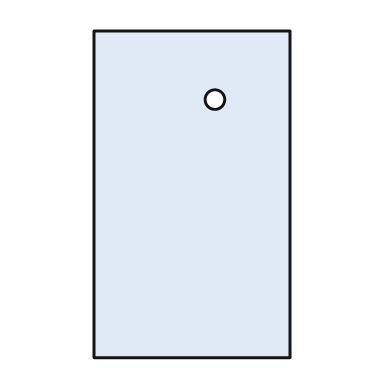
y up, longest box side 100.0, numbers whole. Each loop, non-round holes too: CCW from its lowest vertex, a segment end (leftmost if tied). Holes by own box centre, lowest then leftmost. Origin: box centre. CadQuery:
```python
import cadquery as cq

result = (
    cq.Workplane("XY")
    .moveTo(-30.0, -50.0)
    .lineTo(30.0, -50.0)
    .lineTo(30.0, 50.0)
    .lineTo(-30.0, 50.0)
    .close()
    .moveTo(7.0, 29.0)
    .circle(3.0)
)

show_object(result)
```